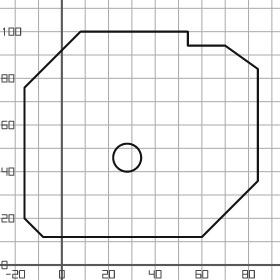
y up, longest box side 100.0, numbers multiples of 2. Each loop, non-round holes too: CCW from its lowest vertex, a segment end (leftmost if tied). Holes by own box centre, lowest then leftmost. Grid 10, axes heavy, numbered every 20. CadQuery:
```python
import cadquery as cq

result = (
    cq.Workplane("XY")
    .moveTo(-8.0, 12.0)
    .lineTo(60.0, 12.0)
    .lineTo(84.0, 36.0)
    .lineTo(84.0, 84.0)
    .lineTo(70.0, 94.0)
    .lineTo(54.0, 94.0)
    .lineTo(54.0, 100.0)
    .lineTo(8.0, 100.0)
    .lineTo(-16.0, 76.0)
    .lineTo(-16.0, 20.0)
    .close()
    .moveTo(28.0, 46.0)
    .circle(6.0)
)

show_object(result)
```